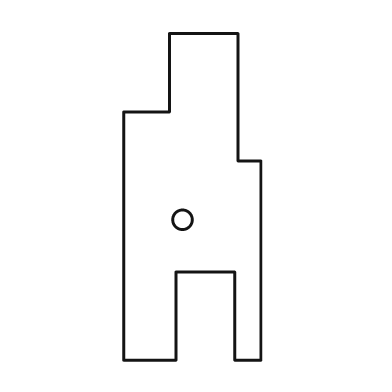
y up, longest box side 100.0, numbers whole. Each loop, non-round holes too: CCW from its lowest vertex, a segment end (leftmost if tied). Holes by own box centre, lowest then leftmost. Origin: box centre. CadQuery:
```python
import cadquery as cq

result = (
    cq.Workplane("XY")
    .moveTo(-21.0, -50.0)
    .lineTo(-5.0, -50.0)
    .lineTo(-5.0, -23.0)
    .lineTo(13.0, -23.0)
    .lineTo(13.0, -50.0)
    .lineTo(21.0, -50.0)
    .lineTo(21.0, 11.0)
    .lineTo(14.0, 11.0)
    .lineTo(14.0, 50.0)
    .lineTo(-7.0, 50.0)
    .lineTo(-7.0, 26.0)
    .lineTo(-21.0, 26.0)
    .close()
    .moveTo(-3.0, -7.0)
    .circle(3.0)
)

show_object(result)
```